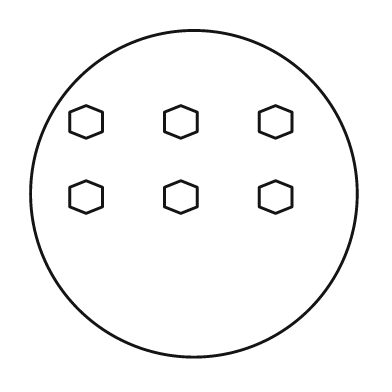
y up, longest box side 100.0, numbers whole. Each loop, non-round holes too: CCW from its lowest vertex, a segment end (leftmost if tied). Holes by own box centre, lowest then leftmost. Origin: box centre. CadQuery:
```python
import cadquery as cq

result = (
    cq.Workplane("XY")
    .moveTo(0.0, 0.0)
    .circle(50.0)
    .moveTo(-33.0, -6.0)
    .lineTo(-28.0, -4.0)
    .lineTo(-28.0, 2.0)
    .lineTo(-33.0, 4.0)
    .lineTo(-38.0, 2.0)
    .lineTo(-38.0, -4.0)
    .close()
    .moveTo(-4.0, -6.0)
    .lineTo(1.0, -4.0)
    .lineTo(1.0, 2.0)
    .lineTo(-4.0, 4.0)
    .lineTo(-9.0, 2.0)
    .lineTo(-9.0, -4.0)
    .close()
    .moveTo(25.0, -6.0)
    .lineTo(30.0, -4.0)
    .lineTo(30.0, 2.0)
    .lineTo(25.0, 4.0)
    .lineTo(20.0, 2.0)
    .lineTo(20.0, -4.0)
    .close()
    .moveTo(-33.0, 17.0)
    .lineTo(-28.0, 19.0)
    .lineTo(-28.0, 25.0)
    .lineTo(-33.0, 27.0)
    .lineTo(-38.0, 25.0)
    .lineTo(-38.0, 19.0)
    .close()
    .moveTo(-4.0, 17.0)
    .lineTo(1.0, 19.0)
    .lineTo(1.0, 25.0)
    .lineTo(-4.0, 27.0)
    .lineTo(-9.0, 25.0)
    .lineTo(-9.0, 19.0)
    .close()
    .moveTo(25.0, 17.0)
    .lineTo(30.0, 19.0)
    .lineTo(30.0, 25.0)
    .lineTo(25.0, 27.0)
    .lineTo(20.0, 25.0)
    .lineTo(20.0, 19.0)
    .close()
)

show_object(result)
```